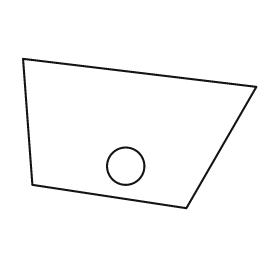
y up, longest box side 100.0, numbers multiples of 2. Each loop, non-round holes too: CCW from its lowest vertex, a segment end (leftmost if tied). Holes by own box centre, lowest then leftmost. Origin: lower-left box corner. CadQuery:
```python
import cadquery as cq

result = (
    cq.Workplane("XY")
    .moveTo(70.0, 0.0)
    .lineTo(100.0, 52.0)
    .lineTo(0.0, 64.0)
    .lineTo(4.0, 10.0)
    .close()
    .moveTo(44.0, 18.0)
    .circle(8.0)
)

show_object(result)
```